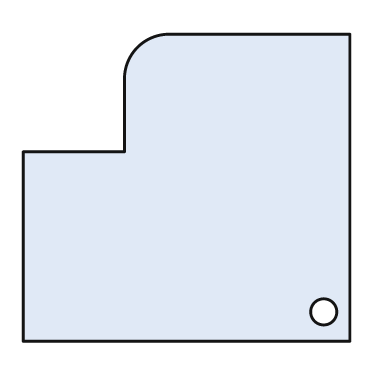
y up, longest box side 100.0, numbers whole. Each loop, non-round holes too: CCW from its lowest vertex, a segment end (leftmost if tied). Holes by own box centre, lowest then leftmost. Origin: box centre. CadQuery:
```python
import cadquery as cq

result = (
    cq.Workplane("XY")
    .moveTo(-50.0, -47.0)
    .lineTo(50.0, -47.0)
    .lineTo(50.0, 47.0)
    .lineTo(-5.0, 47.0)
    .threePointArc((-15.0, 43.0), (-19.0, 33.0))
    .lineTo(-19.0, 11.0)
    .lineTo(-50.0, 11.0)
    .close()
    .moveTo(42.0, -38.0)
    .circle(4.0)
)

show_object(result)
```